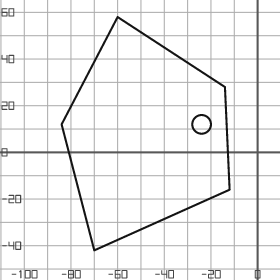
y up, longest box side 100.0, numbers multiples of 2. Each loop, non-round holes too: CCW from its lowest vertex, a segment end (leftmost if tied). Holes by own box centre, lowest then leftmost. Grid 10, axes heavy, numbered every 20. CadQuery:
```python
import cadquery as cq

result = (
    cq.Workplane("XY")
    .moveTo(-70.0, -42.0)
    .lineTo(-12.0, -16.0)
    .lineTo(-14.0, 28.0)
    .lineTo(-60.0, 58.0)
    .lineTo(-84.0, 12.0)
    .close()
    .moveTo(-24.0, 12.0)
    .circle(4.0)
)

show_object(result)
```